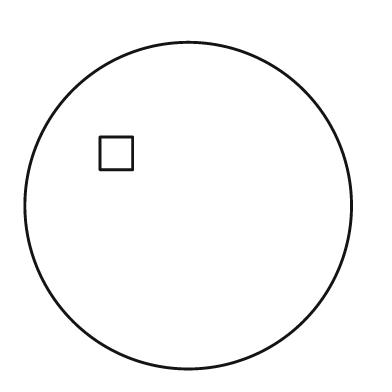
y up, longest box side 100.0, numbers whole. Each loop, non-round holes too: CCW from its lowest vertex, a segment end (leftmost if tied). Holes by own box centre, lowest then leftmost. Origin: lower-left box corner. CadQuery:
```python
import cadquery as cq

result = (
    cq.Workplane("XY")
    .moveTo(50.0, 50.0)
    .circle(50.0)
    .moveTo(23.0, 61.0)
    .lineTo(33.0, 61.0)
    .lineTo(33.0, 71.0)
    .lineTo(23.0, 71.0)
    .close()
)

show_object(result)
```